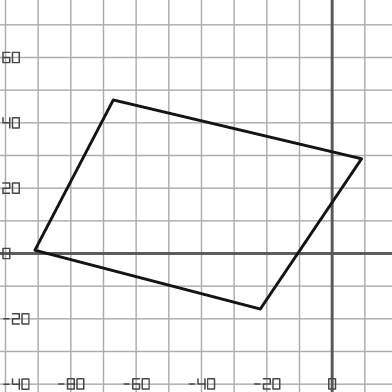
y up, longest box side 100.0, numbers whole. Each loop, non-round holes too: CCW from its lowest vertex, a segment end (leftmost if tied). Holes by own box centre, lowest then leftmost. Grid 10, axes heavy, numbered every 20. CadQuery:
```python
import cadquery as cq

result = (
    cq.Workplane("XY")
    .moveTo(-22.0, -17.0)
    .lineTo(9.0, 29.0)
    .lineTo(-67.0, 47.0)
    .lineTo(-91.0, 1.0)
    .close()
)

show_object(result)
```